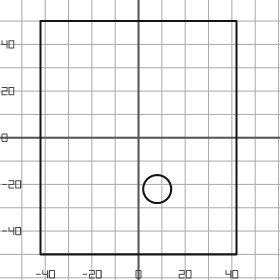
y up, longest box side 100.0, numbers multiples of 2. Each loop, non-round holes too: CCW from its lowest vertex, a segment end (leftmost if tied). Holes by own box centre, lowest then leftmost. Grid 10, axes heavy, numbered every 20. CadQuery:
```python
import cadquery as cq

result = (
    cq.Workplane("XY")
    .moveTo(-42.0, -50.0)
    .lineTo(42.0, -50.0)
    .lineTo(42.0, 50.0)
    .lineTo(-42.0, 50.0)
    .close()
    .moveTo(8.0, -22.0)
    .circle(6.0)
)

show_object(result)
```